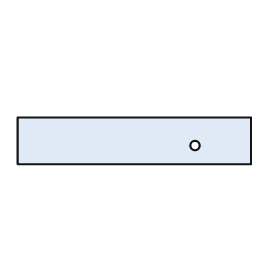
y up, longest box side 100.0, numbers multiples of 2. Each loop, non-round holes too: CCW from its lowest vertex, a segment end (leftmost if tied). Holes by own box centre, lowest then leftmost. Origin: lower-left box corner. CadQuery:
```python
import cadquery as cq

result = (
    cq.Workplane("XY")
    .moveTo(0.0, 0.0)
    .lineTo(100.0, 0.0)
    .lineTo(100.0, 20.0)
    .lineTo(0.0, 20.0)
    .close()
    .moveTo(76.0, 8.0)
    .circle(2.0)
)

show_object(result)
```